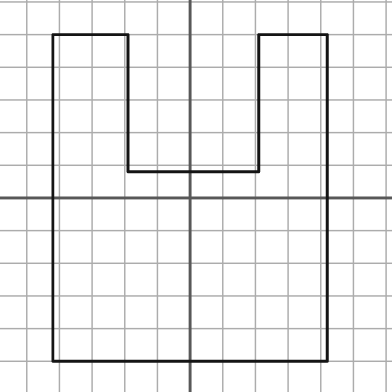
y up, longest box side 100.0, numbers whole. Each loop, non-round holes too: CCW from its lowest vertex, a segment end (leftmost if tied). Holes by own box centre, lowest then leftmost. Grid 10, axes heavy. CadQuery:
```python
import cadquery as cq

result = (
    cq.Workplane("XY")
    .moveTo(-42.0, -50.0)
    .lineTo(42.0, -50.0)
    .lineTo(42.0, 50.0)
    .lineTo(21.0, 50.0)
    .lineTo(21.0, 8.0)
    .lineTo(-19.0, 8.0)
    .lineTo(-19.0, 50.0)
    .lineTo(-42.0, 50.0)
    .close()
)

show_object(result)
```